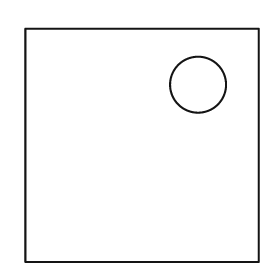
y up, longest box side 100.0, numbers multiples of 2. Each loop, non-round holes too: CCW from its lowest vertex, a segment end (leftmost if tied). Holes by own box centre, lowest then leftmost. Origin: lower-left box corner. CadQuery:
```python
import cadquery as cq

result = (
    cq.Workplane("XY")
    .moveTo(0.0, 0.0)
    .lineTo(100.0, 0.0)
    .lineTo(100.0, 100.0)
    .lineTo(0.0, 100.0)
    .close()
    .moveTo(74.0, 76.0)
    .circle(12.0)
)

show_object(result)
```